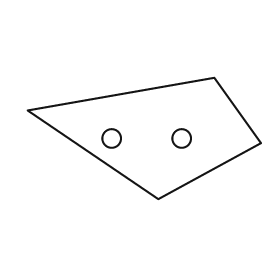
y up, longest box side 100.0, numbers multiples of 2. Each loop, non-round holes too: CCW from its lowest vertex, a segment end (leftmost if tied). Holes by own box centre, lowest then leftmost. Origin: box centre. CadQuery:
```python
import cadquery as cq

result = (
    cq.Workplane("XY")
    .moveTo(6.0, -26.0)
    .lineTo(50.0, -2.0)
    .lineTo(30.0, 26.0)
    .lineTo(-50.0, 12.0)
    .close()
    .moveTo(-14.0, 0.0)
    .circle(4.0)
    .moveTo(16.0, 0.0)
    .circle(4.0)
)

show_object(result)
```